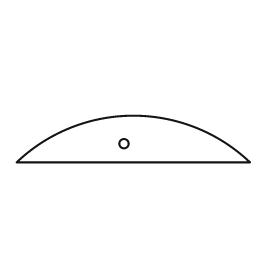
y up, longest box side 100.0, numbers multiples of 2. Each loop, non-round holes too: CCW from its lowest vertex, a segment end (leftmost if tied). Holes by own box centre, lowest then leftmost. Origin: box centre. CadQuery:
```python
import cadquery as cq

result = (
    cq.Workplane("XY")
    .moveTo(-50.0, -10.0)
    .lineTo(50.0, -10.0)
    .threePointArc((0.0, 10.0), (-50.0, -10.0))
    .close()
    .moveTo(-4.0, -2.0)
    .circle(2.0)
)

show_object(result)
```